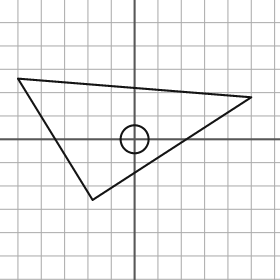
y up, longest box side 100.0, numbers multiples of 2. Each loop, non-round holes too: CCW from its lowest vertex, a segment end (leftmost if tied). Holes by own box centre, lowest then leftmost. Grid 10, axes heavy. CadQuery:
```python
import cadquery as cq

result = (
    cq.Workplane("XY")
    .moveTo(-18.0, -26.0)
    .lineTo(50.0, 18.0)
    .lineTo(-50.0, 26.0)
    .close()
    .moveTo(0.0, 0.0)
    .circle(6.0)
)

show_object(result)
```